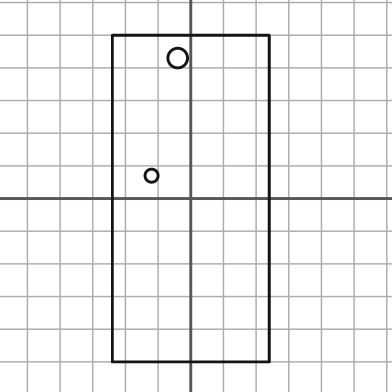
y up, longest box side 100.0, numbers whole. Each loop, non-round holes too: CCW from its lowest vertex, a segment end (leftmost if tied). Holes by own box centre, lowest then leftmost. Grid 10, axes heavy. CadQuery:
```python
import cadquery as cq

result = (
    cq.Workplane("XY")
    .moveTo(-24.0, -50.0)
    .lineTo(24.0, -50.0)
    .lineTo(24.0, 50.0)
    .lineTo(-24.0, 50.0)
    .close()
    .moveTo(-12.0, 7.0)
    .circle(2.0)
    .moveTo(-4.0, 43.0)
    .circle(3.0)
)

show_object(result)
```